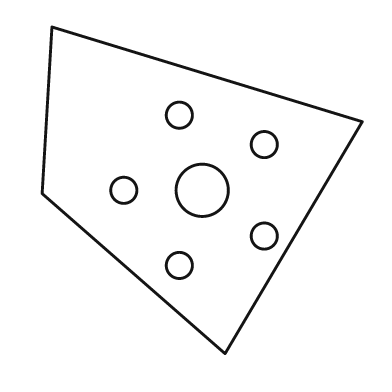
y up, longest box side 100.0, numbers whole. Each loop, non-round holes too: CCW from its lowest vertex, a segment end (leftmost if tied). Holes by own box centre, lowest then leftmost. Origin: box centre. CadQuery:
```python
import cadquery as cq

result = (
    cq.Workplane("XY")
    .moveTo(7.0, -50.0)
    .lineTo(49.0, 21.0)
    .lineTo(-46.0, 50.0)
    .lineTo(-49.0, -1.0)
    .close()
    .moveTo(-7.0, -23.0)
    .circle(4.0)
    .moveTo(19.0, -14.0)
    .circle(4.0)
    .moveTo(-24.0, 0.0)
    .circle(4.0)
    .moveTo(0.0, 0.0)
    .circle(8.0)
    .moveTo(19.0, 14.0)
    .circle(4.0)
    .moveTo(-7.0, 23.0)
    .circle(4.0)
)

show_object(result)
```